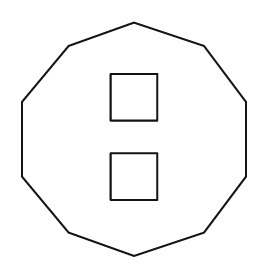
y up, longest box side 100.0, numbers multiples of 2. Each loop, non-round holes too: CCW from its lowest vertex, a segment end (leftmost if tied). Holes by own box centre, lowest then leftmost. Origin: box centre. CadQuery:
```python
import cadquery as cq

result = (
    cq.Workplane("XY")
    .moveTo(0.0, -50.0)
    .lineTo(30.0, -40.0)
    .lineTo(48.0, -16.0)
    .lineTo(48.0, 16.0)
    .lineTo(30.0, 40.0)
    .lineTo(0.0, 50.0)
    .lineTo(-28.0, 40.0)
    .lineTo(-48.0, 16.0)
    .lineTo(-48.0, -16.0)
    .lineTo(-28.0, -40.0)
    .close()
    .moveTo(-10.0, -26.0)
    .lineTo(10.0, -26.0)
    .lineTo(10.0, -6.0)
    .lineTo(-10.0, -6.0)
    .close()
    .moveTo(-10.0, 8.0)
    .lineTo(10.0, 8.0)
    .lineTo(10.0, 28.0)
    .lineTo(-10.0, 28.0)
    .close()
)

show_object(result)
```